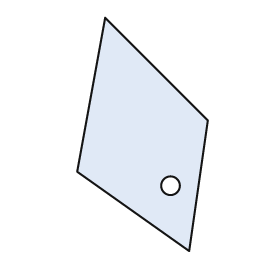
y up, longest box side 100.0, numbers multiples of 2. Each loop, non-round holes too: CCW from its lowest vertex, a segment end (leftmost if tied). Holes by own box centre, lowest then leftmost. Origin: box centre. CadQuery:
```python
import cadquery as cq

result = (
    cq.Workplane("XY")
    .moveTo(20.0, -50.0)
    .lineTo(28.0, 6.0)
    .lineTo(-16.0, 50.0)
    .lineTo(-28.0, -16.0)
    .close()
    .moveTo(12.0, -22.0)
    .circle(4.0)
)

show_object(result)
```